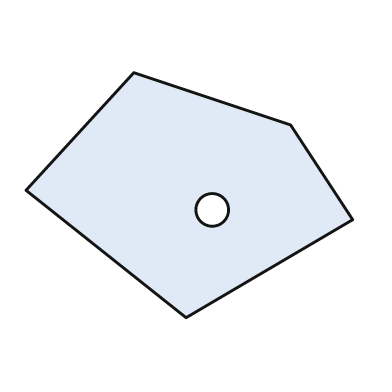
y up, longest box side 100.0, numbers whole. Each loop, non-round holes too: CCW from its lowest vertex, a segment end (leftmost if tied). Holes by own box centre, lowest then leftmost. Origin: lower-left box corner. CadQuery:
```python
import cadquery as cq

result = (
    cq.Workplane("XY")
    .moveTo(49.0, 0.0)
    .lineTo(100.0, 30.0)
    .lineTo(81.0, 59.0)
    .lineTo(33.0, 75.0)
    .lineTo(0.0, 39.0)
    .close()
    .moveTo(57.0, 33.0)
    .circle(5.0)
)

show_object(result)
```